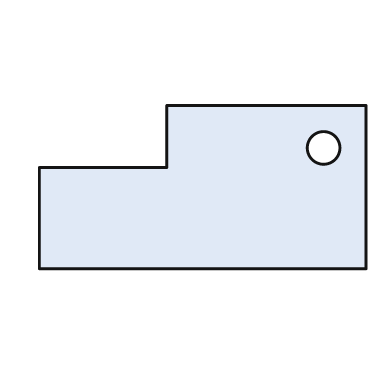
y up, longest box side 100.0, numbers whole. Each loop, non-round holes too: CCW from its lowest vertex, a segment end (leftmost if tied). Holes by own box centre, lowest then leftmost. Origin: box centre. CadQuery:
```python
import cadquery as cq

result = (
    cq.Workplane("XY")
    .moveTo(-50.0, -25.0)
    .lineTo(50.0, -25.0)
    .lineTo(50.0, 25.0)
    .lineTo(-11.0, 25.0)
    .lineTo(-11.0, 6.0)
    .lineTo(-50.0, 6.0)
    .close()
    .moveTo(37.0, 12.0)
    .circle(5.0)
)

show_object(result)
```